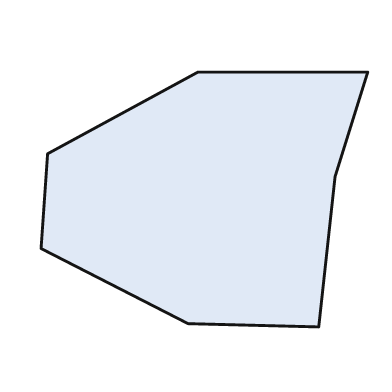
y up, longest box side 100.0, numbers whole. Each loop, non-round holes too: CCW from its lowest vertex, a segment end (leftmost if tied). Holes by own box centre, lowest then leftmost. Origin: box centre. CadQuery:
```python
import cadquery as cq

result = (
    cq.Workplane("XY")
    .moveTo(35.0, -39.0)
    .lineTo(40.0, 7.0)
    .lineTo(50.0, 39.0)
    .lineTo(-2.0, 39.0)
    .lineTo(-48.0, 14.0)
    .lineTo(-50.0, -15.0)
    .lineTo(-5.0, -38.0)
    .close()
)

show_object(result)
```